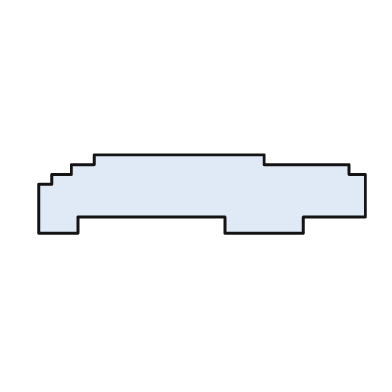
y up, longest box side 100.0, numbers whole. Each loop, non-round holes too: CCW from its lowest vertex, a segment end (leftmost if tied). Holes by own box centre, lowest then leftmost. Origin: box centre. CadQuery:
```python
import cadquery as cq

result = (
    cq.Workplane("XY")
    .moveTo(-50.0, -12.0)
    .lineTo(-38.0, -12.0)
    .lineTo(-38.0, -7.0)
    .lineTo(7.0, -7.0)
    .lineTo(7.0, -12.0)
    .lineTo(31.0, -12.0)
    .lineTo(31.0, -7.0)
    .lineTo(50.0, -7.0)
    .lineTo(50.0, 6.0)
    .lineTo(45.0, 6.0)
    .lineTo(45.0, 9.0)
    .lineTo(19.0, 9.0)
    .lineTo(19.0, 12.0)
    .lineTo(-33.0, 12.0)
    .lineTo(-33.0, 9.0)
    .lineTo(-40.0, 9.0)
    .lineTo(-40.0, 6.0)
    .lineTo(-46.0, 6.0)
    .lineTo(-46.0, 3.0)
    .lineTo(-50.0, 3.0)
    .close()
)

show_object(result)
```